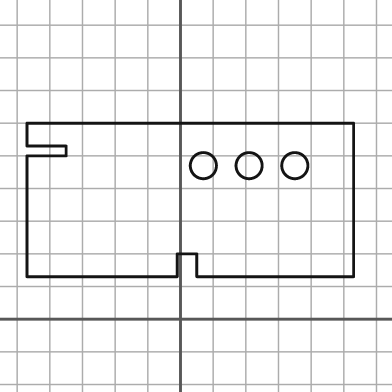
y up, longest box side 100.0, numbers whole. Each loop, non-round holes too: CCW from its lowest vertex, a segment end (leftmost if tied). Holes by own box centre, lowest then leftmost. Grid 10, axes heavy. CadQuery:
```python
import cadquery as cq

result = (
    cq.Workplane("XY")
    .moveTo(-47.0, 13.0)
    .lineTo(-1.0, 13.0)
    .lineTo(-1.0, 20.0)
    .lineTo(5.0, 20.0)
    .lineTo(5.0, 13.0)
    .lineTo(53.0, 13.0)
    .lineTo(53.0, 60.0)
    .lineTo(-47.0, 60.0)
    .lineTo(-47.0, 53.0)
    .lineTo(-35.0, 53.0)
    .lineTo(-35.0, 50.0)
    .lineTo(-47.0, 50.0)
    .close()
    .moveTo(7.0, 47.0)
    .circle(4.0)
    .moveTo(21.0, 47.0)
    .circle(4.0)
    .moveTo(35.0, 47.0)
    .circle(4.0)
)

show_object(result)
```